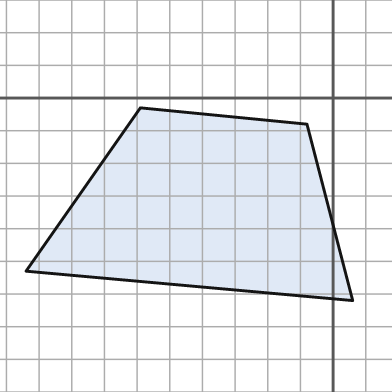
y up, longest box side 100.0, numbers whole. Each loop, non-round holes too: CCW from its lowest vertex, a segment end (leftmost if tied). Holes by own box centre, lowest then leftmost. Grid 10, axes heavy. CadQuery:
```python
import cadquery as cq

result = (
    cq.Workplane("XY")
    .moveTo(6.0, -62.0)
    .lineTo(-8.0, -8.0)
    .lineTo(-59.0, -3.0)
    .lineTo(-94.0, -53.0)
    .close()
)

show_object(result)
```